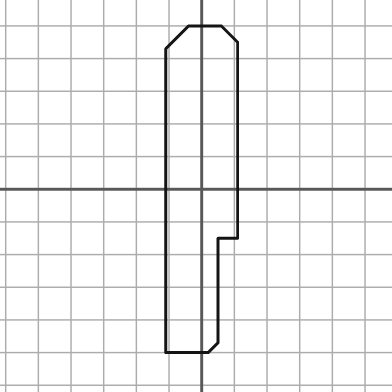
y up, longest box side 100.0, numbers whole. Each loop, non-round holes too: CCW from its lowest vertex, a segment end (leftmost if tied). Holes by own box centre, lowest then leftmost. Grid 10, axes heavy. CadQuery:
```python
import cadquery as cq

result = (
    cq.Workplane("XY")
    .moveTo(-11.0, -50.0)
    .lineTo(2.0, -50.0)
    .lineTo(5.0, -47.0)
    .lineTo(5.0, -15.0)
    .lineTo(11.0, -15.0)
    .lineTo(11.0, 45.0)
    .lineTo(6.0, 50.0)
    .lineTo(-4.0, 50.0)
    .lineTo(-11.0, 43.0)
    .close()
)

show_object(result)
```